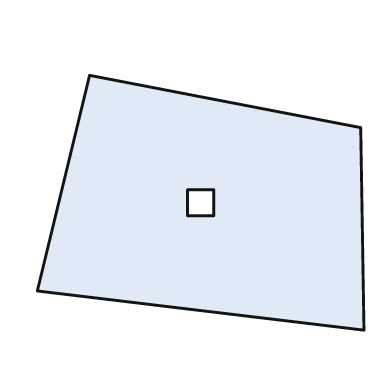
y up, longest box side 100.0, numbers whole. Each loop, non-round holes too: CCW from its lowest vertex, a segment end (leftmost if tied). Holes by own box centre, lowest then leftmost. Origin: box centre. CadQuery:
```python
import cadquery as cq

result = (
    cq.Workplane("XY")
    .moveTo(50.0, -39.0)
    .lineTo(49.0, 23.0)
    .lineTo(-34.0, 39.0)
    .lineTo(-50.0, -27.0)
    .close()
    .moveTo(-4.0, -4.0)
    .lineTo(4.0, -4.0)
    .lineTo(4.0, 4.0)
    .lineTo(-4.0, 4.0)
    .close()
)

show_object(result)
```